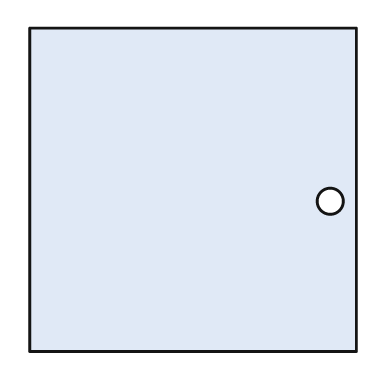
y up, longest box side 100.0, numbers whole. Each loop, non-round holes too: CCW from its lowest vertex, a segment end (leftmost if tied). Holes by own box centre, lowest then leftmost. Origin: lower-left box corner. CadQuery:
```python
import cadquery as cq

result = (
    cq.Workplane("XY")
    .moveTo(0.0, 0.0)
    .lineTo(100.0, 0.0)
    .lineTo(100.0, 99.0)
    .lineTo(0.0, 99.0)
    .close()
    .moveTo(92.0, 46.0)
    .circle(4.0)
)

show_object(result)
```